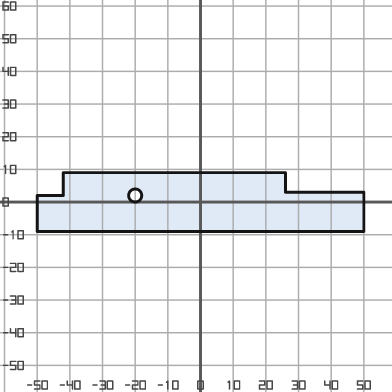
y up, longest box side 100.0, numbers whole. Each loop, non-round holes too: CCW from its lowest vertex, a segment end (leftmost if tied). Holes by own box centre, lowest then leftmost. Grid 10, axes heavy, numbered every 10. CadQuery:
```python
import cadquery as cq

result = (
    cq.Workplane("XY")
    .moveTo(-50.0, -9.0)
    .lineTo(50.0, -9.0)
    .lineTo(50.0, 3.0)
    .lineTo(26.0, 3.0)
    .lineTo(26.0, 9.0)
    .lineTo(-42.0, 9.0)
    .lineTo(-42.0, 2.0)
    .lineTo(-50.0, 2.0)
    .close()
    .moveTo(-20.0, 2.0)
    .circle(2.0)
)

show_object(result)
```